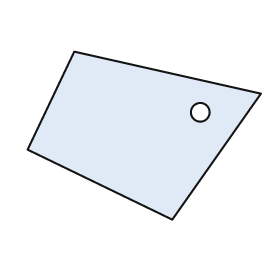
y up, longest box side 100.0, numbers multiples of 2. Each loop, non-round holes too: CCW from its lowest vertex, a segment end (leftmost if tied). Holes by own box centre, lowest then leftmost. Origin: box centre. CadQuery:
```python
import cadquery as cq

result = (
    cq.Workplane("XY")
    .moveTo(12.0, -36.0)
    .lineTo(50.0, 18.0)
    .lineTo(-30.0, 36.0)
    .lineTo(-50.0, -6.0)
    .close()
    .moveTo(24.0, 10.0)
    .circle(4.0)
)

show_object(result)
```